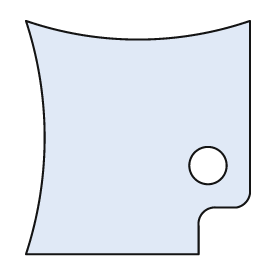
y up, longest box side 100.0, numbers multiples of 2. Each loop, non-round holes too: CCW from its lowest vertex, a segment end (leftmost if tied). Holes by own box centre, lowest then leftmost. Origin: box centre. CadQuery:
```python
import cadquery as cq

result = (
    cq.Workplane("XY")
    .moveTo(-48.0, -50.0)
    .lineTo(26.0, -50.0)
    .lineTo(26.0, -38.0)
    .threePointArc((28.0, -32.0), (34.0, -30.0))
    .lineTo(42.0, -30.0)
    .threePointArc((46.0, -28.0), (48.0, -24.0))
    .lineTo(48.0, 50.0)
    .threePointArc((0.0, 42.0), (-48.0, 50.0))
    .threePointArc((-40.0, 0.0), (-48.0, -50.0))
    .close()
    .moveTo(30.0, -12.0)
    .circle(8.0)
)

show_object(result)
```